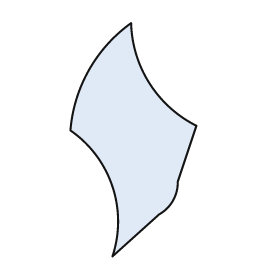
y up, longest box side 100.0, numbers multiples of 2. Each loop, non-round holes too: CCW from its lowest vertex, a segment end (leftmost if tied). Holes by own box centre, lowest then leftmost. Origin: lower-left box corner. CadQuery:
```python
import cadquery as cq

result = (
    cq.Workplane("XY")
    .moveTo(18.0, 0.0)
    .lineTo(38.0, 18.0)
    .threePointArc((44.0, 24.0), (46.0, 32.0))
    .lineTo(54.0, 56.0)
    .threePointArc((34.0, 74.0), (26.0, 100.0))
    .threePointArc((8.0, 80.0), (0.0, 54.0))
    .threePointArc((18.0, 30.0), (18.0, 0.0))
    .close()
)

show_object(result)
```